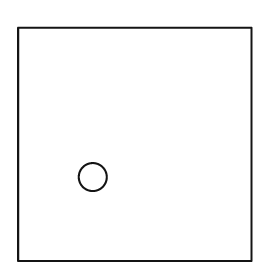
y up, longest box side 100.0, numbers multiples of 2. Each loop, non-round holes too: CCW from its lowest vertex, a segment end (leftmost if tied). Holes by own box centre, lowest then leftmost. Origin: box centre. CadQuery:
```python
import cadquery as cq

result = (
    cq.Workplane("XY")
    .moveTo(-50.0, -50.0)
    .lineTo(50.0, -50.0)
    .lineTo(50.0, 50.0)
    .lineTo(-50.0, 50.0)
    .close()
    .moveTo(-18.0, -14.0)
    .circle(6.0)
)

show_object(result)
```